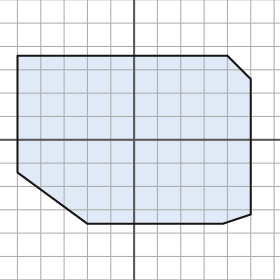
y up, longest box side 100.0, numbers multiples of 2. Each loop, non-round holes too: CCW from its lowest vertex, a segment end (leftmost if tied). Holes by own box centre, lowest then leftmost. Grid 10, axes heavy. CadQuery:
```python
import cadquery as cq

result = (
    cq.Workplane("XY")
    .moveTo(-20.0, -36.0)
    .lineTo(38.0, -36.0)
    .lineTo(50.0, -32.0)
    .lineTo(50.0, 26.0)
    .lineTo(40.0, 36.0)
    .lineTo(-50.0, 36.0)
    .lineTo(-50.0, -14.0)
    .close()
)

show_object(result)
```